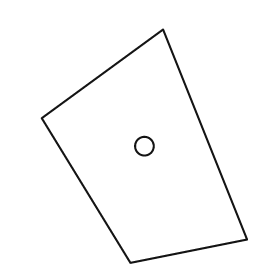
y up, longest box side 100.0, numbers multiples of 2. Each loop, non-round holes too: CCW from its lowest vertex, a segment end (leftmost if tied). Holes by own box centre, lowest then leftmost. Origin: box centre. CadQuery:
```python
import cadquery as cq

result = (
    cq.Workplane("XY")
    .moveTo(-6.0, -50.0)
    .lineTo(44.0, -40.0)
    .lineTo(8.0, 50.0)
    .lineTo(-44.0, 12.0)
    .close()
    .moveTo(0.0, 0.0)
    .circle(4.0)
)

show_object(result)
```